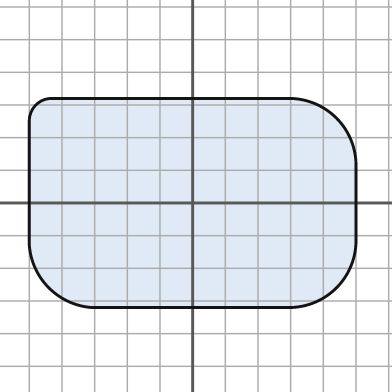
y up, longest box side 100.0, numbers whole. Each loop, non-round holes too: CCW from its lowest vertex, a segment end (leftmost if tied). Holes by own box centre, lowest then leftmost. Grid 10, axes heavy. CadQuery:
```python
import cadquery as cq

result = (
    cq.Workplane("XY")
    .moveTo(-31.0, -32.0)
    .lineTo(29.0, -32.0)
    .threePointArc((44.0, -26.0), (50.0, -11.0))
    .lineTo(50.0, 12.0)
    .threePointArc((44.0, 26.0), (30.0, 32.0))
    .lineTo(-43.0, 32.0)
    .threePointArc((-48.0, 30.0), (-50.0, 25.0))
    .lineTo(-50.0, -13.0)
    .threePointArc((-44.0, -26.0), (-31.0, -32.0))
    .close()
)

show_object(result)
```